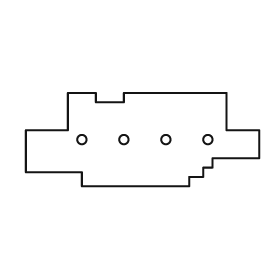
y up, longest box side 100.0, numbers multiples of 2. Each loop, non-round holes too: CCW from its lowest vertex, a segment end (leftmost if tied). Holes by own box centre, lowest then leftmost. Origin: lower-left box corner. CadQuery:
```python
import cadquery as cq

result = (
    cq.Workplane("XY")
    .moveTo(24.0, 0.0)
    .lineTo(70.0, 0.0)
    .lineTo(70.0, 4.0)
    .lineTo(76.0, 4.0)
    .lineTo(76.0, 8.0)
    .lineTo(80.0, 8.0)
    .lineTo(80.0, 12.0)
    .lineTo(100.0, 12.0)
    .lineTo(100.0, 24.0)
    .lineTo(86.0, 24.0)
    .lineTo(86.0, 40.0)
    .lineTo(42.0, 40.0)
    .lineTo(42.0, 36.0)
    .lineTo(30.0, 36.0)
    .lineTo(30.0, 40.0)
    .lineTo(18.0, 40.0)
    .lineTo(18.0, 24.0)
    .lineTo(0.0, 24.0)
    .lineTo(0.0, 6.0)
    .lineTo(24.0, 6.0)
    .close()
    .moveTo(24.0, 20.0)
    .circle(2.0)
    .moveTo(42.0, 20.0)
    .circle(2.0)
    .moveTo(60.0, 20.0)
    .circle(2.0)
    .moveTo(78.0, 20.0)
    .circle(2.0)
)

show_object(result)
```